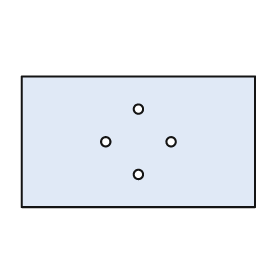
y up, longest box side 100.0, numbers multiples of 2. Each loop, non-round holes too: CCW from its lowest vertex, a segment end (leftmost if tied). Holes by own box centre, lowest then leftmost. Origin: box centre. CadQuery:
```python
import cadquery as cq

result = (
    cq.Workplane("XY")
    .moveTo(-50.0, -28.0)
    .lineTo(50.0, -28.0)
    .lineTo(50.0, 28.0)
    .lineTo(-50.0, 28.0)
    .close()
    .moveTo(0.0, -14.0)
    .circle(2.0)
    .moveTo(-14.0, 0.0)
    .circle(2.0)
    .moveTo(14.0, 0.0)
    .circle(2.0)
    .moveTo(0.0, 14.0)
    .circle(2.0)
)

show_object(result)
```